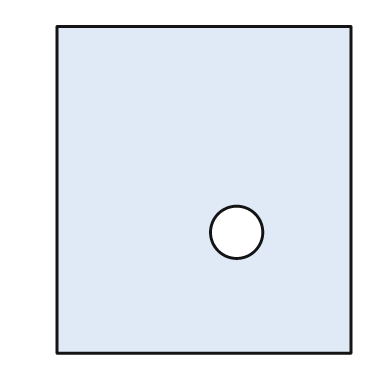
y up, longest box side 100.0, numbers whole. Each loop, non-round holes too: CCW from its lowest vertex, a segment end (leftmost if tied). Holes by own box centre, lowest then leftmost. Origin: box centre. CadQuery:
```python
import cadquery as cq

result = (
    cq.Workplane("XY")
    .moveTo(-45.0, -50.0)
    .lineTo(45.0, -50.0)
    .lineTo(45.0, 50.0)
    .lineTo(-45.0, 50.0)
    .close()
    .moveTo(10.0, -13.0)
    .circle(8.0)
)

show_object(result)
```